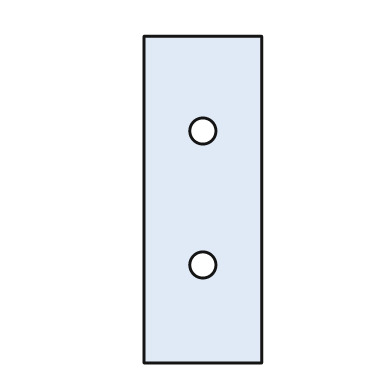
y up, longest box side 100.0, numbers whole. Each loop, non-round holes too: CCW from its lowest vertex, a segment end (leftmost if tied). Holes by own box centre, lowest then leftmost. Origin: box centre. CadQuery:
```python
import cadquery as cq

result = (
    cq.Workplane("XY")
    .moveTo(-18.0, -50.0)
    .lineTo(18.0, -50.0)
    .lineTo(18.0, 50.0)
    .lineTo(-18.0, 50.0)
    .close()
    .moveTo(0.0, -20.0)
    .circle(4.0)
    .moveTo(0.0, 21.0)
    .circle(4.0)
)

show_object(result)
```